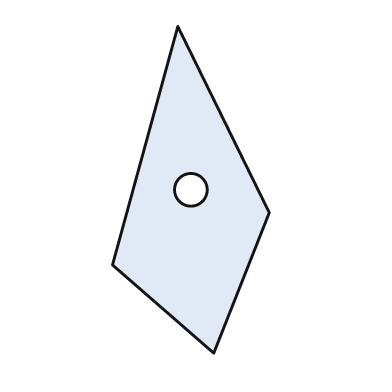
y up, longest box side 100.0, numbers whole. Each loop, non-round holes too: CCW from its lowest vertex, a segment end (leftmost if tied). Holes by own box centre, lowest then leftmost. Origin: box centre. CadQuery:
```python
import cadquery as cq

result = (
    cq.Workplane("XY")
    .moveTo(7.0, -50.0)
    .lineTo(24.0, -7.0)
    .lineTo(-4.0, 50.0)
    .lineTo(-24.0, -23.0)
    .close()
    .moveTo(0.0, 0.0)
    .circle(5.0)
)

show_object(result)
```